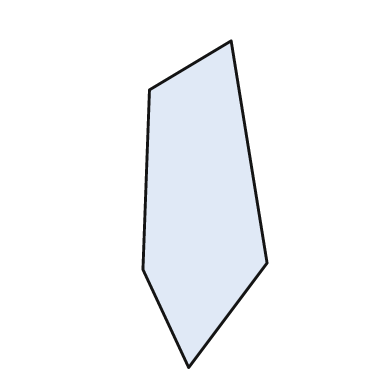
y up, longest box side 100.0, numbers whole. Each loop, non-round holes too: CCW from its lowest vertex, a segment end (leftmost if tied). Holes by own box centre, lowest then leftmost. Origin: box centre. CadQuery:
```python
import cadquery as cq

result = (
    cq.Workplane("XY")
    .moveTo(-5.0, -50.0)
    .lineTo(19.0, -18.0)
    .lineTo(8.0, 50.0)
    .lineTo(-17.0, 35.0)
    .lineTo(-19.0, -20.0)
    .close()
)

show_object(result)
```